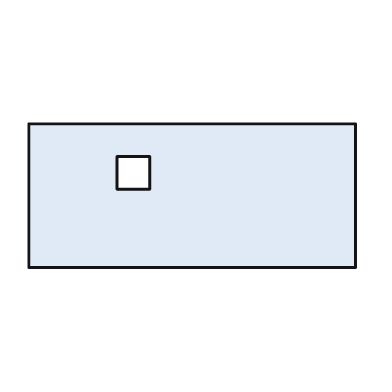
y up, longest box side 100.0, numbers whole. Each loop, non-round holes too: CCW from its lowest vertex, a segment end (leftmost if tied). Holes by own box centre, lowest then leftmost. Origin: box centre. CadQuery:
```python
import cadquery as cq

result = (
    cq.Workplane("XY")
    .moveTo(-50.0, -22.0)
    .lineTo(50.0, -22.0)
    .lineTo(50.0, 22.0)
    .lineTo(-50.0, 22.0)
    .close()
    .moveTo(-23.0, 2.0)
    .lineTo(-13.0, 2.0)
    .lineTo(-13.0, 12.0)
    .lineTo(-23.0, 12.0)
    .close()
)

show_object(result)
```